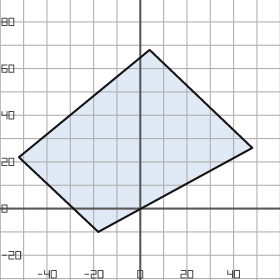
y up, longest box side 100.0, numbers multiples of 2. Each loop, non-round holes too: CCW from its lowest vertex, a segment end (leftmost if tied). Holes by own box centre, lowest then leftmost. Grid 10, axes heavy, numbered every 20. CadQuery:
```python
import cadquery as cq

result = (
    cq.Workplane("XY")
    .moveTo(-18.0, -10.0)
    .lineTo(48.0, 26.0)
    .lineTo(4.0, 68.0)
    .lineTo(-52.0, 22.0)
    .close()
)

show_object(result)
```